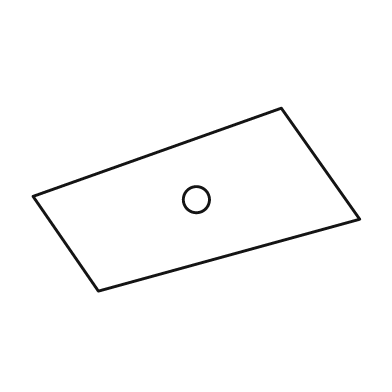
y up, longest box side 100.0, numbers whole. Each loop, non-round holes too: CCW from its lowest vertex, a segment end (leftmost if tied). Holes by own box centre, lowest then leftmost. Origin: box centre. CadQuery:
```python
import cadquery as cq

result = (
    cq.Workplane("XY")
    .moveTo(-30.0, -28.0)
    .lineTo(50.0, -6.0)
    .lineTo(26.0, 28.0)
    .lineTo(-50.0, 1.0)
    .close()
    .moveTo(0.0, 0.0)
    .circle(4.0)
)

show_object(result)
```